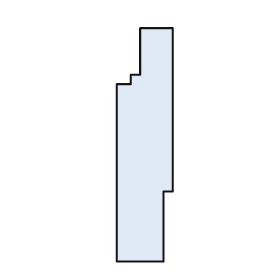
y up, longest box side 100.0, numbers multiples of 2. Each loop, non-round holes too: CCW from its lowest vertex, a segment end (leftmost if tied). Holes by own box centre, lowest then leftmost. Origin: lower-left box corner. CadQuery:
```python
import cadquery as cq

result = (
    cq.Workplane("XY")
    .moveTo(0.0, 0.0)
    .lineTo(20.0, 0.0)
    .lineTo(20.0, 30.0)
    .lineTo(24.0, 30.0)
    .lineTo(24.0, 100.0)
    .lineTo(10.0, 100.0)
    .lineTo(10.0, 80.0)
    .lineTo(6.0, 80.0)
    .lineTo(6.0, 76.0)
    .lineTo(0.0, 76.0)
    .close()
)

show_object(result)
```